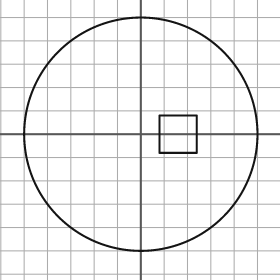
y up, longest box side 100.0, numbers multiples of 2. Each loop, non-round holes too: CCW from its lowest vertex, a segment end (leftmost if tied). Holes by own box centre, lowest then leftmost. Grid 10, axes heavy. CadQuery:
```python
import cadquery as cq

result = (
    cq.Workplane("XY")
    .moveTo(0.0, 0.0)
    .circle(50.0)
    .moveTo(8.0, -8.0)
    .lineTo(24.0, -8.0)
    .lineTo(24.0, 8.0)
    .lineTo(8.0, 8.0)
    .close()
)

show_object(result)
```